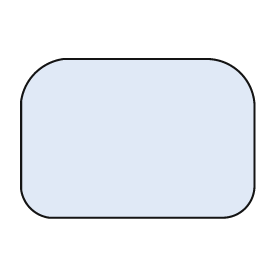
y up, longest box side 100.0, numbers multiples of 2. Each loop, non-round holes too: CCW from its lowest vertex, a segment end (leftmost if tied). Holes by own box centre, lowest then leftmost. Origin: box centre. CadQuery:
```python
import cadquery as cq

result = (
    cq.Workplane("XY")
    .moveTo(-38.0, -34.0)
    .lineTo(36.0, -34.0)
    .threePointArc((46.0, -30.0), (50.0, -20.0))
    .lineTo(50.0, 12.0)
    .threePointArc((44.0, 28.0), (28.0, 34.0))
    .lineTo(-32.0, 34.0)
    .threePointArc((-44.0, 28.0), (-50.0, 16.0))
    .lineTo(-50.0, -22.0)
    .threePointArc((-46.0, -30.0), (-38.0, -34.0))
    .close()
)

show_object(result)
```